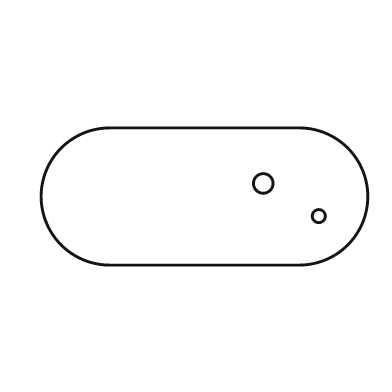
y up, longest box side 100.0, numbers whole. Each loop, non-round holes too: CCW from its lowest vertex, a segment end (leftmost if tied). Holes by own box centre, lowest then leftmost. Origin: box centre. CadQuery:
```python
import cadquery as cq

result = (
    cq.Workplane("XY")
    .moveTo(-29.0, -21.0)
    .lineTo(29.0, -21.0)
    .threePointArc((50.0, 0.0), (29.0, 21.0))
    .lineTo(-29.0, 21.0)
    .threePointArc((-50.0, 0.0), (-29.0, -21.0))
    .close()
    .moveTo(35.0, -6.0)
    .circle(2.0)
    .moveTo(18.0, 4.0)
    .circle(3.0)
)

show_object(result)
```